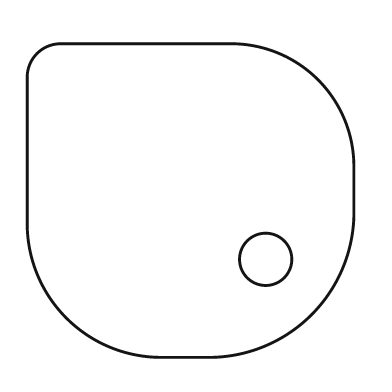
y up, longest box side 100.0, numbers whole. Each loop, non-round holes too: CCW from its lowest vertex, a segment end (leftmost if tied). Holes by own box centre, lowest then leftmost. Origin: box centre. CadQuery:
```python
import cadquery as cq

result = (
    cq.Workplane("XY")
    .moveTo(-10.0, -48.0)
    .lineTo(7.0, -48.0)
    .threePointArc((37.0, -35.0), (50.0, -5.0))
    .lineTo(50.0, 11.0)
    .threePointArc((39.0, 37.0), (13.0, 48.0))
    .lineTo(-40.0, 48.0)
    .threePointArc((-47.0, 45.0), (-50.0, 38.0))
    .lineTo(-50.0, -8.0)
    .threePointArc((-38.0, -36.0), (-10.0, -48.0))
    .close()
    .moveTo(23.0, -18.0)
    .circle(8.0)
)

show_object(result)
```